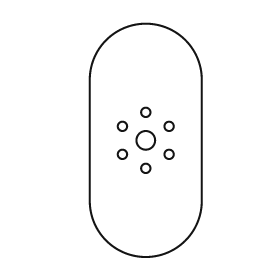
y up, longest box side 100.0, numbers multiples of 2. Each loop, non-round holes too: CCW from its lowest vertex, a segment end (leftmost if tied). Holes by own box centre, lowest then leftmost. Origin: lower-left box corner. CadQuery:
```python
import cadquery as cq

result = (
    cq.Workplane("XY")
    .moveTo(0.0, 24.0)
    .threePointArc((24.0, 0.0), (48.0, 24.0))
    .lineTo(48.0, 76.0)
    .threePointArc((24.0, 100.0), (0.0, 76.0))
    .close()
    .moveTo(24.0, 38.0)
    .circle(2.0)
    .moveTo(14.0, 44.0)
    .circle(2.0)
    .moveTo(34.0, 44.0)
    .circle(2.0)
    .moveTo(24.0, 50.0)
    .circle(4.0)
    .moveTo(14.0, 56.0)
    .circle(2.0)
    .moveTo(34.0, 56.0)
    .circle(2.0)
    .moveTo(24.0, 62.0)
    .circle(2.0)
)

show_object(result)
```